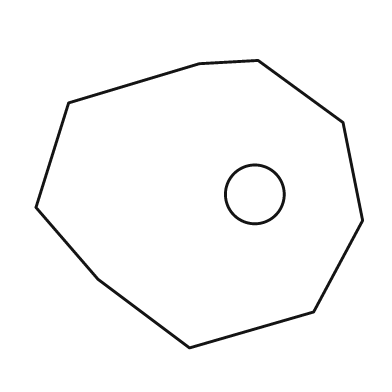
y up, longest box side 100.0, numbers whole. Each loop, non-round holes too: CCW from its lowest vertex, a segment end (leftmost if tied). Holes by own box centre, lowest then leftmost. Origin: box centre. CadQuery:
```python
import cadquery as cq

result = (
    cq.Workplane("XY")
    .moveTo(-3.0, -44.0)
    .lineTo(35.0, -33.0)
    .lineTo(50.0, -5.0)
    .lineTo(44.0, 25.0)
    .lineTo(18.0, 44.0)
    .lineTo(0.0, 43.0)
    .lineTo(-40.0, 31.0)
    .lineTo(-50.0, -1.0)
    .lineTo(-31.0, -23.0)
    .close()
    .moveTo(17.0, 3.0)
    .circle(9.0)
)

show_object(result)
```